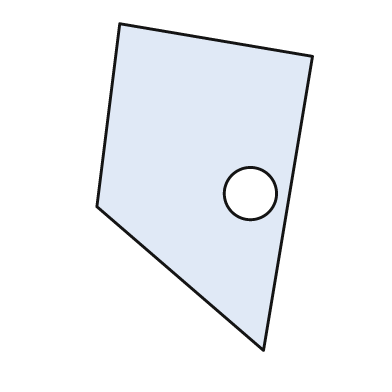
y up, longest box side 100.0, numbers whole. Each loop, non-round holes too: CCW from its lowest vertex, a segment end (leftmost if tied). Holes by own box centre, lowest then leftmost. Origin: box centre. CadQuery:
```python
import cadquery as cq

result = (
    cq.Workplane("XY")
    .moveTo(18.0, -50.0)
    .lineTo(33.0, 40.0)
    .lineTo(-26.0, 50.0)
    .lineTo(-33.0, -6.0)
    .close()
    .moveTo(14.0, -2.0)
    .circle(8.0)
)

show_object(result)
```